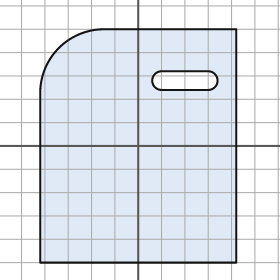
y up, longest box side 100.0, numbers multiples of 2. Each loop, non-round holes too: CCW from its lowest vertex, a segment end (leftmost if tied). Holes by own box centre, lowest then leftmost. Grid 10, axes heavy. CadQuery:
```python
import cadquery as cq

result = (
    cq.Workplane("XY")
    .moveTo(-42.0, -50.0)
    .lineTo(42.0, -50.0)
    .lineTo(42.0, 50.0)
    .lineTo(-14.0, 50.0)
    .threePointArc((-34.0, 42.0), (-42.0, 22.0))
    .close()
    .moveTo(10.0, 24.0)
    .lineTo(30.0, 24.0)
    .threePointArc((34.0, 28.0), (30.0, 32.0))
    .lineTo(10.0, 32.0)
    .threePointArc((6.0, 28.0), (10.0, 24.0))
    .close()
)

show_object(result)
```